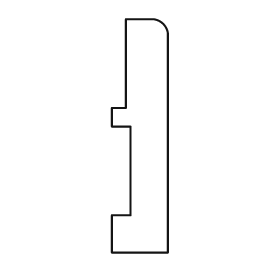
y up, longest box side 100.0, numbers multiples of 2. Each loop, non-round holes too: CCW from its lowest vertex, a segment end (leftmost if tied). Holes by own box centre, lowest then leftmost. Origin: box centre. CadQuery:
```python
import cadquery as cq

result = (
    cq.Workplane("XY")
    .moveTo(-12.0, -50.0)
    .lineTo(12.0, -50.0)
    .lineTo(12.0, 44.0)
    .threePointArc((10.0, 48.0), (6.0, 50.0))
    .lineTo(-6.0, 50.0)
    .lineTo(-6.0, 12.0)
    .lineTo(-12.0, 12.0)
    .lineTo(-12.0, 4.0)
    .lineTo(-4.0, 4.0)
    .lineTo(-4.0, -34.0)
    .lineTo(-12.0, -34.0)
    .close()
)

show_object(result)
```